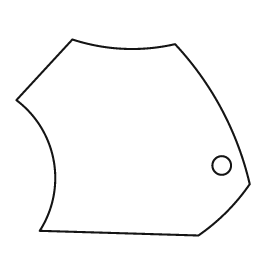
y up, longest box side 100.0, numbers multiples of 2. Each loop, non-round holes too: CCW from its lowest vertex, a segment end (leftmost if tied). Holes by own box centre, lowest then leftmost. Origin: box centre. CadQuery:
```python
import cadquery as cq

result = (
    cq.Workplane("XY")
    .moveTo(28.0, -42.0)
    .threePointArc((40.0, -32.0), (50.0, -20.0))
    .threePointArc((38.0, 12.0), (18.0, 40.0))
    .threePointArc((-4.0, 38.0), (-26.0, 42.0))
    .lineTo(-50.0, 16.0)
    .threePointArc((-34.0, -10.0), (-40.0, -40.0))
    .close()
    .moveTo(38.0, -12.0)
    .circle(4.0)
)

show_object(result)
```